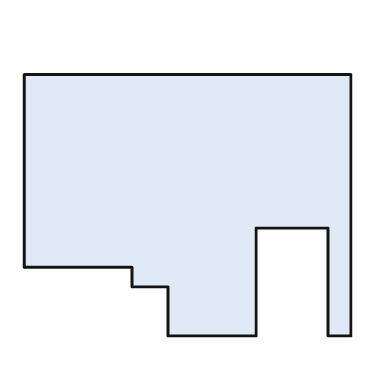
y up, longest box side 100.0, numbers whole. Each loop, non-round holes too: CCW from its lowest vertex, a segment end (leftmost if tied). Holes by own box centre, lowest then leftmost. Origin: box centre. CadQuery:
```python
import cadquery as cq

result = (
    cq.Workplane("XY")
    .moveTo(-6.0, -40.0)
    .lineTo(21.0, -40.0)
    .lineTo(21.0, -7.0)
    .lineTo(43.0, -7.0)
    .lineTo(43.0, -40.0)
    .lineTo(50.0, -40.0)
    .lineTo(50.0, 40.0)
    .lineTo(-50.0, 40.0)
    .lineTo(-50.0, -19.0)
    .lineTo(-17.0, -19.0)
    .lineTo(-17.0, -25.0)
    .lineTo(-6.0, -25.0)
    .close()
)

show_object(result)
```